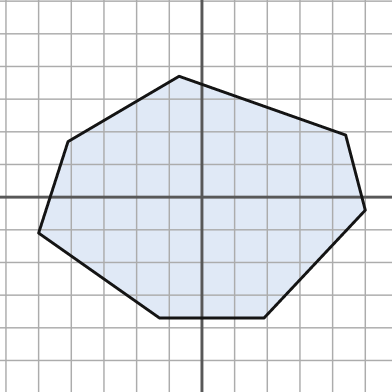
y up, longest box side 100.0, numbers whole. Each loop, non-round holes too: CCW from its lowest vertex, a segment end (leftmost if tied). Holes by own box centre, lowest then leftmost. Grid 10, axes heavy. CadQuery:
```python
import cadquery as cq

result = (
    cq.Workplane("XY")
    .moveTo(-13.0, -37.0)
    .lineTo(19.0, -37.0)
    .lineTo(50.0, -4.0)
    .lineTo(44.0, 19.0)
    .lineTo(-7.0, 37.0)
    .lineTo(-41.0, 17.0)
    .lineTo(-50.0, -11.0)
    .close()
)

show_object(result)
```